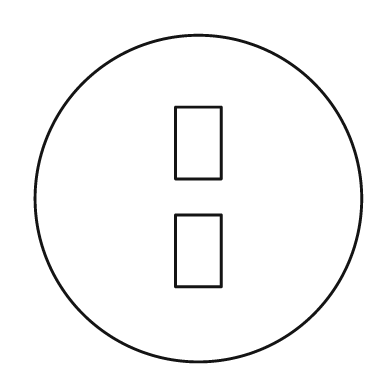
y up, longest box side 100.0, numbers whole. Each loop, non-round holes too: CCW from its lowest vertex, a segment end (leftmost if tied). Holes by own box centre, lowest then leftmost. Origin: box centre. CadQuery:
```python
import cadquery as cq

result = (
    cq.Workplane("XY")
    .moveTo(0.0, 0.0)
    .circle(50.0)
    .moveTo(-7.0, -27.0)
    .lineTo(7.0, -27.0)
    .lineTo(7.0, -5.0)
    .lineTo(-7.0, -5.0)
    .close()
    .moveTo(-7.0, 6.0)
    .lineTo(7.0, 6.0)
    .lineTo(7.0, 28.0)
    .lineTo(-7.0, 28.0)
    .close()
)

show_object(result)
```